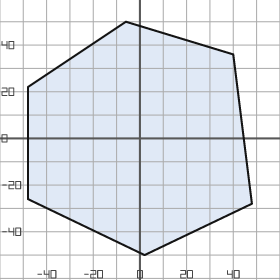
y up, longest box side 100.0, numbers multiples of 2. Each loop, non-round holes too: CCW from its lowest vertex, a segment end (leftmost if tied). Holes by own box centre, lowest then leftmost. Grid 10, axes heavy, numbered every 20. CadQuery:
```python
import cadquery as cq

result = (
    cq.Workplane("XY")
    .moveTo(2.0, -50.0)
    .lineTo(48.0, -28.0)
    .lineTo(40.0, 36.0)
    .lineTo(-6.0, 50.0)
    .lineTo(-48.0, 22.0)
    .lineTo(-48.0, -26.0)
    .close()
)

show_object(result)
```